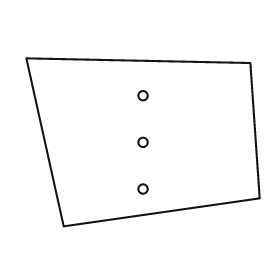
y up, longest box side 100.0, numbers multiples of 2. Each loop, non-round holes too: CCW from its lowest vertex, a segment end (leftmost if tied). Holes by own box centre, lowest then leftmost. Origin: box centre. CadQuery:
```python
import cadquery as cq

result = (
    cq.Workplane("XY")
    .moveTo(-34.0, -36.0)
    .lineTo(50.0, -24.0)
    .lineTo(46.0, 34.0)
    .lineTo(-50.0, 36.0)
    .close()
    .moveTo(0.0, -20.0)
    .circle(2.0)
    .moveTo(0.0, 0.0)
    .circle(2.0)
    .moveTo(0.0, 20.0)
    .circle(2.0)
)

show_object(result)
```